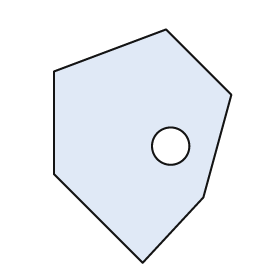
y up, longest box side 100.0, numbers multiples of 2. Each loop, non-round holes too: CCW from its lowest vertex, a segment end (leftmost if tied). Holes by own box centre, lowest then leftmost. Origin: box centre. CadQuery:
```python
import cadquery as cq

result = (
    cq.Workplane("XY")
    .moveTo(0.0, -50.0)
    .lineTo(26.0, -22.0)
    .lineTo(38.0, 22.0)
    .lineTo(10.0, 50.0)
    .lineTo(-38.0, 32.0)
    .lineTo(-38.0, -12.0)
    .close()
    .moveTo(12.0, 0.0)
    .circle(8.0)
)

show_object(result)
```